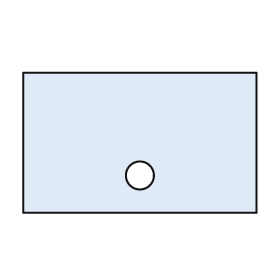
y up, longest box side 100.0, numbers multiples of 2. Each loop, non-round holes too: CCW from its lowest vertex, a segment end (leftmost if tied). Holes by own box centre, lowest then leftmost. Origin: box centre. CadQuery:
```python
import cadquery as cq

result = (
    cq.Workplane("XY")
    .moveTo(-50.0, -30.0)
    .lineTo(50.0, -30.0)
    .lineTo(50.0, 30.0)
    .lineTo(-50.0, 30.0)
    .close()
    .moveTo(0.0, -14.0)
    .circle(6.0)
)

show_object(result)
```